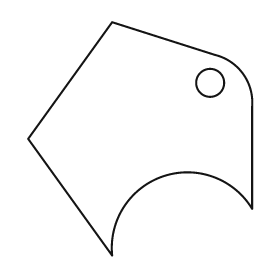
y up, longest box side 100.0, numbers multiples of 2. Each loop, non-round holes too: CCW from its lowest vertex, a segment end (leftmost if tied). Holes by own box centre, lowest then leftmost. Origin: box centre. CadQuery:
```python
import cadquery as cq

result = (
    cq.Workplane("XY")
    .moveTo(-12.0, -50.0)
    .threePointArc((10.0, -16.0), (48.0, -30.0))
    .lineTo(48.0, 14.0)
    .threePointArc((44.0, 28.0), (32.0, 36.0))
    .lineTo(-12.0, 50.0)
    .lineTo(-48.0, 0.0)
    .close()
    .moveTo(30.0, 24.0)
    .circle(6.0)
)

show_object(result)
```